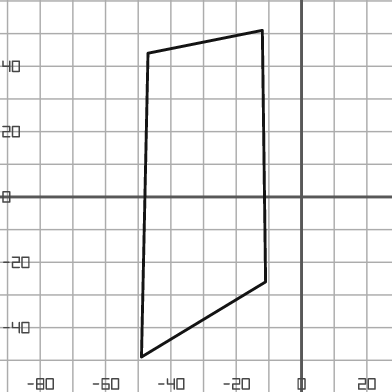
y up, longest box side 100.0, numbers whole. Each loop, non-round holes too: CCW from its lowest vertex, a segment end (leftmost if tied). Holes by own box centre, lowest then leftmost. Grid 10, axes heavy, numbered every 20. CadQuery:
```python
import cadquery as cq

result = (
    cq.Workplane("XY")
    .moveTo(-49.0, -49.0)
    .lineTo(-11.0, -26.0)
    .lineTo(-12.0, 51.0)
    .lineTo(-47.0, 44.0)
    .close()
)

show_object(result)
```